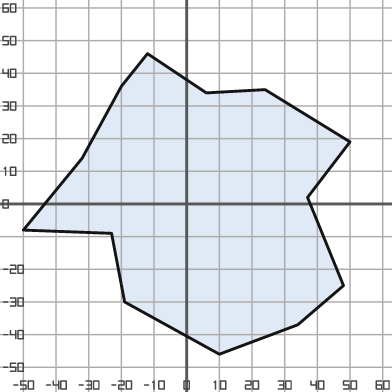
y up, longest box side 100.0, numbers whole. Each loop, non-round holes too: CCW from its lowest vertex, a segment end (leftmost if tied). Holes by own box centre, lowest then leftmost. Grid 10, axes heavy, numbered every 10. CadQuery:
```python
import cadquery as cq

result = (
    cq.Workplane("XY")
    .moveTo(10.0, -46.0)
    .lineTo(34.0, -37.0)
    .lineTo(48.0, -25.0)
    .lineTo(37.0, 2.0)
    .lineTo(50.0, 19.0)
    .lineTo(24.0, 35.0)
    .lineTo(6.0, 34.0)
    .lineTo(-12.0, 46.0)
    .lineTo(-20.0, 36.0)
    .lineTo(-32.0, 14.0)
    .lineTo(-50.0, -8.0)
    .lineTo(-23.0, -9.0)
    .lineTo(-19.0, -30.0)
    .close()
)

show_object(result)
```